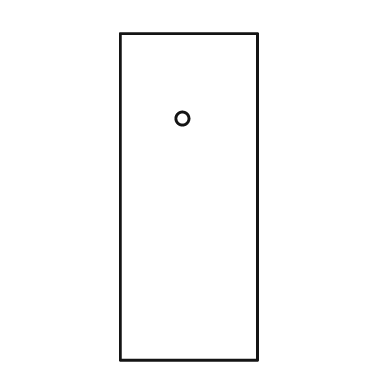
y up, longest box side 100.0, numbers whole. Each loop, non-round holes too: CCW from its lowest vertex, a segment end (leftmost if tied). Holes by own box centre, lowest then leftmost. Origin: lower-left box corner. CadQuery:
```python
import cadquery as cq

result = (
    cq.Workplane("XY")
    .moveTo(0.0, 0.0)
    .lineTo(42.0, 0.0)
    .lineTo(42.0, 100.0)
    .lineTo(0.0, 100.0)
    .close()
    .moveTo(19.0, 74.0)
    .circle(2.0)
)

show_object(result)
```